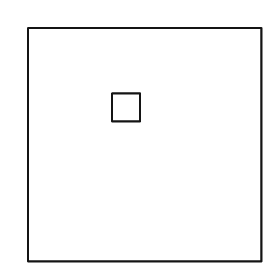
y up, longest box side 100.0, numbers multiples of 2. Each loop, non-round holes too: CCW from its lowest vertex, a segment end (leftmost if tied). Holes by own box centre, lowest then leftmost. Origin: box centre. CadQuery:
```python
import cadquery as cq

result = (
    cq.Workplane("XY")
    .moveTo(-50.0, -50.0)
    .lineTo(50.0, -50.0)
    .lineTo(50.0, 50.0)
    .lineTo(-50.0, 50.0)
    .close()
    .moveTo(-14.0, 10.0)
    .lineTo(-2.0, 10.0)
    .lineTo(-2.0, 22.0)
    .lineTo(-14.0, 22.0)
    .close()
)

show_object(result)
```